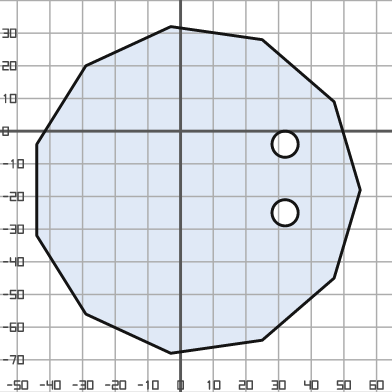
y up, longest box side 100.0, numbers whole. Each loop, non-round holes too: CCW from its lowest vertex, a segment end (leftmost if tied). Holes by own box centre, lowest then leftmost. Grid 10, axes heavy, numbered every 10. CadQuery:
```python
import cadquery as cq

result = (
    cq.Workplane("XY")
    .moveTo(-3.0, -68.0)
    .lineTo(25.0, -64.0)
    .lineTo(47.0, -45.0)
    .lineTo(55.0, -18.0)
    .lineTo(47.0, 9.0)
    .lineTo(25.0, 28.0)
    .lineTo(-3.0, 32.0)
    .lineTo(-29.0, 20.0)
    .lineTo(-44.0, -4.0)
    .lineTo(-44.0, -32.0)
    .lineTo(-29.0, -56.0)
    .close()
    .moveTo(32.0, -25.0)
    .circle(4.0)
    .moveTo(32.0, -4.0)
    .circle(4.0)
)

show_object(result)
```